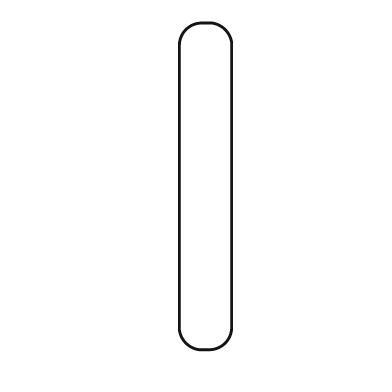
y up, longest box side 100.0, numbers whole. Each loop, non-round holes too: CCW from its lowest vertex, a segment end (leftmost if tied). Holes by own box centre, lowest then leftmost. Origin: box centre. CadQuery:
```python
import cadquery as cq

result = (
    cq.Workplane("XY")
    .moveTo(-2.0, -50.0)
    .lineTo(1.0, -50.0)
    .threePointArc((6.0, -48.0), (8.0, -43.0))
    .lineTo(8.0, 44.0)
    .threePointArc((6.0, 48.0), (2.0, 50.0))
    .lineTo(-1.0, 50.0)
    .threePointArc((-6.0, 48.0), (-8.0, 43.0))
    .lineTo(-8.0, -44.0)
    .threePointArc((-6.0, -48.0), (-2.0, -50.0))
    .close()
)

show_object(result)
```